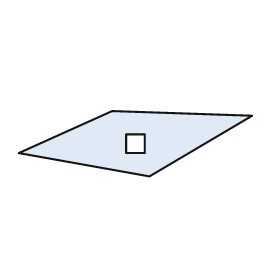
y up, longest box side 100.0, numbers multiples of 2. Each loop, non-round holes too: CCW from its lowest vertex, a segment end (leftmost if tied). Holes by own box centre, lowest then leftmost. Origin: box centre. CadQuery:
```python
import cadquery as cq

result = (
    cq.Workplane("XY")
    .moveTo(6.0, -14.0)
    .lineTo(50.0, 12.0)
    .lineTo(-10.0, 14.0)
    .lineTo(-50.0, -4.0)
    .close()
    .moveTo(-4.0, -4.0)
    .lineTo(4.0, -4.0)
    .lineTo(4.0, 4.0)
    .lineTo(-4.0, 4.0)
    .close()
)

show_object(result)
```